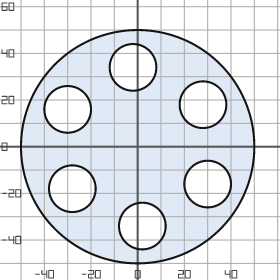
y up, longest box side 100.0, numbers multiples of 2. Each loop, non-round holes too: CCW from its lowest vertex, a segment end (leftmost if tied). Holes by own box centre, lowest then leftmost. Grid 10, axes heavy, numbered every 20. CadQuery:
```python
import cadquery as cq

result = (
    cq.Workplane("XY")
    .moveTo(0.0, 0.0)
    .circle(50.0)
    .moveTo(2.0, -34.0)
    .circle(10.0)
    .moveTo(-28.0, -18.0)
    .circle(10.0)
    .moveTo(30.0, -16.0)
    .circle(10.0)
    .moveTo(-30.0, 16.0)
    .circle(10.0)
    .moveTo(28.0, 18.0)
    .circle(10.0)
    .moveTo(-2.0, 34.0)
    .circle(10.0)
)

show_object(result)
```